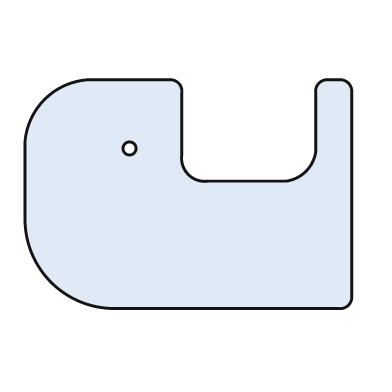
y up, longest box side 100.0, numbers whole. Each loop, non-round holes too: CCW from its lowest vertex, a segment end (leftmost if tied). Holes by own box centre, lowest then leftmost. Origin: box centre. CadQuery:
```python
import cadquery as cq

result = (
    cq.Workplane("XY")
    .moveTo(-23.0, -35.0)
    .lineTo(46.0, -35.0)
    .threePointArc((49.0, -34.0), (50.0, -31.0))
    .lineTo(50.0, 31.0)
    .threePointArc((49.0, 34.0), (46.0, 35.0))
    .lineTo(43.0, 35.0)
    .threePointArc((40.0, 34.0), (39.0, 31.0))
    .lineTo(39.0, 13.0)
    .threePointArc((36.0, 7.0), (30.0, 4.0))
    .lineTo(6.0, 4.0)
    .threePointArc((0.0, 6.0), (-2.0, 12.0))
    .lineTo(-2.0, 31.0)
    .threePointArc((-3.0, 34.0), (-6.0, 35.0))
    .lineTo(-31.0, 35.0)
    .threePointArc((-44.0, 29.0), (-50.0, 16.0))
    .lineTo(-50.0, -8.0)
    .threePointArc((-42.0, -27.0), (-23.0, -35.0))
    .close()
    .moveTo(-18.0, 14.0)
    .circle(2.0)
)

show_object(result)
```